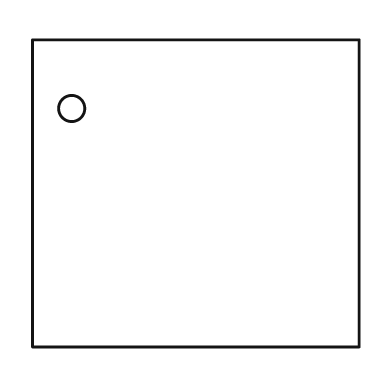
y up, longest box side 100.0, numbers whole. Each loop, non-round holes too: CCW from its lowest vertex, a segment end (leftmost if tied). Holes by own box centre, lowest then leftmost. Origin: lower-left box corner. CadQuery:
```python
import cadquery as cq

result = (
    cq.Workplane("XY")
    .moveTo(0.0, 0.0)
    .lineTo(100.0, 0.0)
    .lineTo(100.0, 94.0)
    .lineTo(0.0, 94.0)
    .close()
    .moveTo(12.0, 73.0)
    .circle(4.0)
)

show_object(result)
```